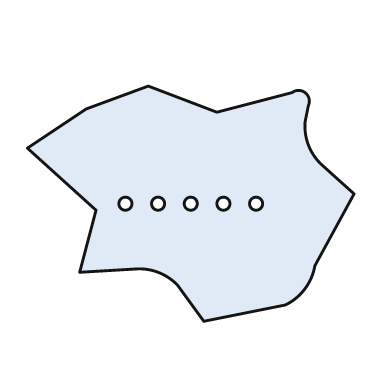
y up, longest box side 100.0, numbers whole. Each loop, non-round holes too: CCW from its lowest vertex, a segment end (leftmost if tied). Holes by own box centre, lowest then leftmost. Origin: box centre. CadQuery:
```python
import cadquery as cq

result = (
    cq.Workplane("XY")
    .moveTo(4.0, -36.0)
    .lineTo(29.0, -31.0)
    .threePointArc((35.0, -26.0), (38.0, -19.0))
    .lineTo(50.0, 3.0)
    .lineTo(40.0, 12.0)
    .threePointArc((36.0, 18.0), (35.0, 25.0))
    .lineTo(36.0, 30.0)
    .threePointArc((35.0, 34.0), (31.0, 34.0))
    .lineTo(8.0, 28.0)
    .lineTo(-13.0, 36.0)
    .lineTo(-32.0, 29.0)
    .lineTo(-50.0, 17.0)
    .lineTo(-29.0, -2.0)
    .lineTo(-34.0, -21.0)
    .lineTo(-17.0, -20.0)
    .threePointArc((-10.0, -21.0), (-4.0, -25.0))
    .close()
    .moveTo(-20.0, 0.0)
    .circle(2.0)
    .moveTo(-10.0, 0.0)
    .circle(2.0)
    .moveTo(0.0, 0.0)
    .circle(2.0)
    .moveTo(10.0, 0.0)
    .circle(2.0)
    .moveTo(20.0, 0.0)
    .circle(2.0)
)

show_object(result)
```